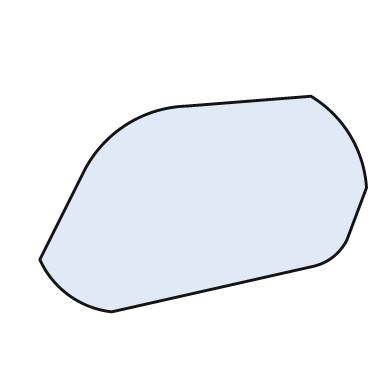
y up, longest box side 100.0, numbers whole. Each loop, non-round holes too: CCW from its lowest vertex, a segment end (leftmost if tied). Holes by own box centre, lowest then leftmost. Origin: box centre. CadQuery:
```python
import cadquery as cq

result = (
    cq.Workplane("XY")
    .moveTo(-28.0, -33.0)
    .lineTo(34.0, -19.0)
    .threePointArc((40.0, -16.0), (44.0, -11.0))
    .lineTo(50.0, 5.0)
    .threePointArc((45.0, 21.0), (33.0, 33.0))
    .lineTo(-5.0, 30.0)
    .threePointArc((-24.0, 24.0), (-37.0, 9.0))
    .lineTo(-50.0, -17.0)
    .threePointArc((-41.0, -28.0), (-28.0, -33.0))
    .close()
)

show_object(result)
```